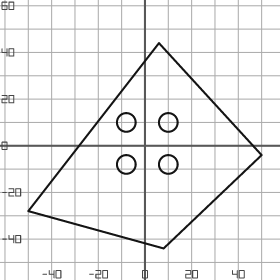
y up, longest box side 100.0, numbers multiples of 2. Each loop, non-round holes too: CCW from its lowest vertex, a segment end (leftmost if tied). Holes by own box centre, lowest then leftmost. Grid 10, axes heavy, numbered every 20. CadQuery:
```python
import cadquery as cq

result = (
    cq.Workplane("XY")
    .moveTo(8.0, -44.0)
    .lineTo(50.0, -4.0)
    .lineTo(6.0, 44.0)
    .lineTo(-50.0, -28.0)
    .close()
    .moveTo(-8.0, -8.0)
    .circle(4.0)
    .moveTo(10.0, -8.0)
    .circle(4.0)
    .moveTo(-8.0, 10.0)
    .circle(4.0)
    .moveTo(10.0, 10.0)
    .circle(4.0)
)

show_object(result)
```